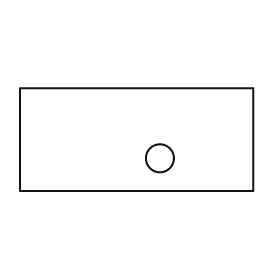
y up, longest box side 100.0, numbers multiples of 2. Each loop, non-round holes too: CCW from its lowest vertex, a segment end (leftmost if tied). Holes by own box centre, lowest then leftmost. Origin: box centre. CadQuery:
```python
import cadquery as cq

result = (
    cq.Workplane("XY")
    .moveTo(-50.0, -22.0)
    .lineTo(50.0, -22.0)
    .lineTo(50.0, 22.0)
    .lineTo(-50.0, 22.0)
    .close()
    .moveTo(10.0, -8.0)
    .circle(6.0)
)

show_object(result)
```